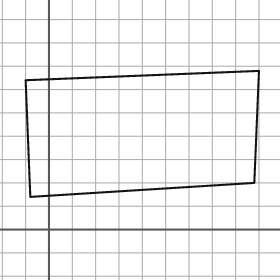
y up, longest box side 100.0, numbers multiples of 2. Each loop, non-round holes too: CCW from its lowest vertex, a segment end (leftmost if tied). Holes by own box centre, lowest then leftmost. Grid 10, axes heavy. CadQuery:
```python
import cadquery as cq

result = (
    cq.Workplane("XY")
    .moveTo(-8.0, 14.0)
    .lineTo(88.0, 20.0)
    .lineTo(90.0, 68.0)
    .lineTo(-10.0, 64.0)
    .close()
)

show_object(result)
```